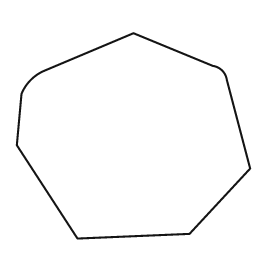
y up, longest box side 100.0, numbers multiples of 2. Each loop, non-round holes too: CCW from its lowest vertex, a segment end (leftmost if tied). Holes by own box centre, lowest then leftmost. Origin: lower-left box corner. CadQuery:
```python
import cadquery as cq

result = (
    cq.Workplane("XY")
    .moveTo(26.0, 0.0)
    .lineTo(74.0, 2.0)
    .lineTo(100.0, 30.0)
    .lineTo(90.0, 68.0)
    .threePointArc((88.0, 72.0), (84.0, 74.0))
    .lineTo(50.0, 88.0)
    .lineTo(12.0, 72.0)
    .threePointArc((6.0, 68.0), (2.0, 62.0))
    .lineTo(0.0, 40.0)
    .close()
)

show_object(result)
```